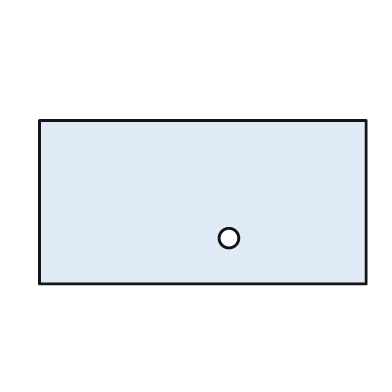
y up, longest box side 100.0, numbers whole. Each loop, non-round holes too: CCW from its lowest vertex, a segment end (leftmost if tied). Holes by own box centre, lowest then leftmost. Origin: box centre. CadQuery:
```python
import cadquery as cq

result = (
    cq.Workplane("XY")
    .moveTo(-50.0, -25.0)
    .lineTo(50.0, -25.0)
    .lineTo(50.0, 25.0)
    .lineTo(-50.0, 25.0)
    .close()
    .moveTo(8.0, -11.0)
    .circle(3.0)
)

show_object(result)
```